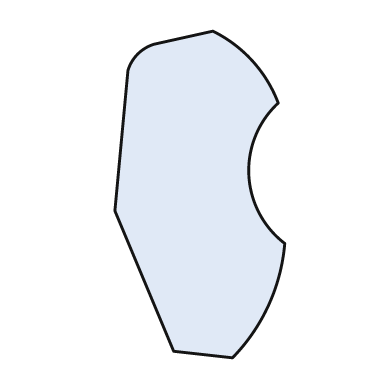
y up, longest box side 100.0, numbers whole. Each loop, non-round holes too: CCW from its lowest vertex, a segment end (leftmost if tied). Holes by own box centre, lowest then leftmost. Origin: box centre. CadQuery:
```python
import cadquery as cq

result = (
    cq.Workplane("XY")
    .moveTo(10.0, -50.0)
    .threePointArc((21.0, -34.0), (26.0, -15.0))
    .threePointArc((15.0, 6.0), (24.0, 28.0))
    .threePointArc((16.0, 41.0), (4.0, 50.0))
    .lineTo(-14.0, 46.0)
    .threePointArc((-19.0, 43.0), (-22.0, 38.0))
    .lineTo(-26.0, -5.0)
    .lineTo(-8.0, -48.0)
    .close()
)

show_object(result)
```